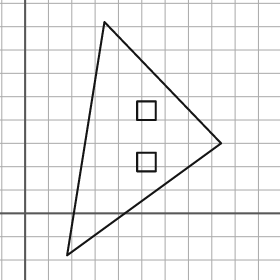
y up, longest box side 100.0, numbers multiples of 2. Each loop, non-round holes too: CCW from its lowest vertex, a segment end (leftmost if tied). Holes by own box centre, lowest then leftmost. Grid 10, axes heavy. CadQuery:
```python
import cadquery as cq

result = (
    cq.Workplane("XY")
    .moveTo(18.0, -18.0)
    .lineTo(84.0, 30.0)
    .lineTo(34.0, 82.0)
    .close()
    .moveTo(48.0, 18.0)
    .lineTo(56.0, 18.0)
    .lineTo(56.0, 26.0)
    .lineTo(48.0, 26.0)
    .close()
    .moveTo(48.0, 40.0)
    .lineTo(56.0, 40.0)
    .lineTo(56.0, 48.0)
    .lineTo(48.0, 48.0)
    .close()
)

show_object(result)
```